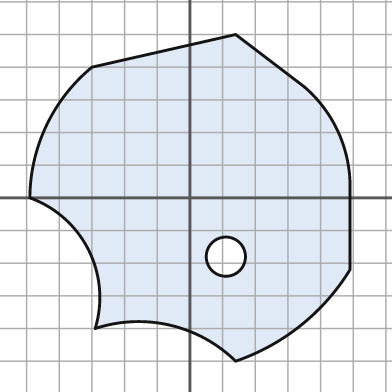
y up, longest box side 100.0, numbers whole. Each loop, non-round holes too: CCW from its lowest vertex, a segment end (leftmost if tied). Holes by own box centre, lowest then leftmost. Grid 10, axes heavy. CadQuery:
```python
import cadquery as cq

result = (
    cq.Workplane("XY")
    .moveTo(14.0, -50.0)
    .threePointArc((34.0, -39.0), (49.0, -22.0))
    .lineTo(49.0, 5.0)
    .threePointArc((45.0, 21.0), (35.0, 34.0))
    .lineTo(14.0, 50.0)
    .lineTo(-30.0, 40.0)
    .threePointArc((-44.0, 22.0), (-49.0, 0.0))
    .threePointArc((-31.0, -16.0), (-29.0, -40.0))
    .threePointArc((-6.0, -39.0), (14.0, -50.0))
    .close()
    .moveTo(11.0, -18.0)
    .circle(6.0)
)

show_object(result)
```